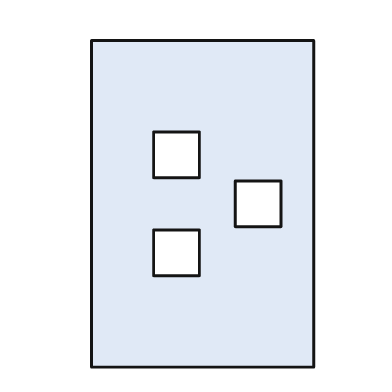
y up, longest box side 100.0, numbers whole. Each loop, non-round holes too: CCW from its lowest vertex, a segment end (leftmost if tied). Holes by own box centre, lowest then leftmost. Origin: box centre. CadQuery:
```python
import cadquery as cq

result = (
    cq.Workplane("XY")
    .moveTo(-34.0, -50.0)
    .lineTo(34.0, -50.0)
    .lineTo(34.0, 50.0)
    .lineTo(-34.0, 50.0)
    .close()
    .moveTo(-15.0, -22.0)
    .lineTo(-1.0, -22.0)
    .lineTo(-1.0, -8.0)
    .lineTo(-15.0, -8.0)
    .close()
    .moveTo(10.0, -7.0)
    .lineTo(24.0, -7.0)
    .lineTo(24.0, 7.0)
    .lineTo(10.0, 7.0)
    .close()
    .moveTo(-15.0, 8.0)
    .lineTo(-1.0, 8.0)
    .lineTo(-1.0, 22.0)
    .lineTo(-15.0, 22.0)
    .close()
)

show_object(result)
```